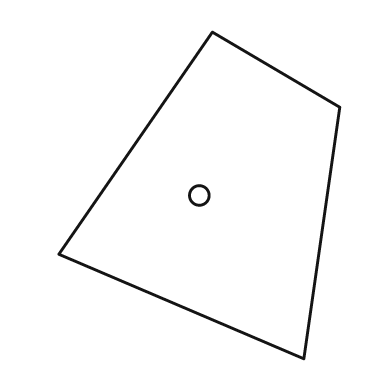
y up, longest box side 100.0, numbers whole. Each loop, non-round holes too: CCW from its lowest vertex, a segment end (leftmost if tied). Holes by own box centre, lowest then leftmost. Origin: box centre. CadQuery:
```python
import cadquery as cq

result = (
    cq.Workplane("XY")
    .moveTo(32.0, -50.0)
    .lineTo(43.0, 27.0)
    .lineTo(4.0, 50.0)
    .lineTo(-43.0, -18.0)
    .close()
    .moveTo(0.0, 0.0)
    .circle(3.0)
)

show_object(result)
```